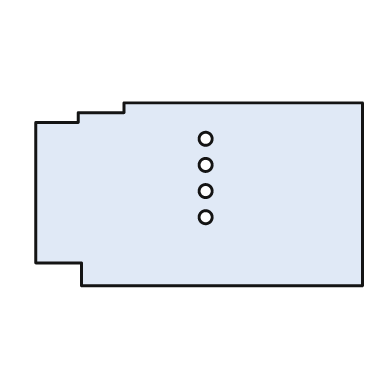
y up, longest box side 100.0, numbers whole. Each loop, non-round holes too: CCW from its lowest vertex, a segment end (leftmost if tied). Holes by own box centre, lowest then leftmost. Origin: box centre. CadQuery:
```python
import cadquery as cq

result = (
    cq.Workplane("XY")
    .moveTo(-36.0, -28.0)
    .lineTo(50.0, -28.0)
    .lineTo(50.0, 28.0)
    .lineTo(-23.0, 28.0)
    .lineTo(-23.0, 25.0)
    .lineTo(-37.0, 25.0)
    .lineTo(-37.0, 22.0)
    .lineTo(-50.0, 22.0)
    .lineTo(-50.0, -21.0)
    .lineTo(-36.0, -21.0)
    .close()
    .moveTo(2.0, -7.0)
    .circle(2.0)
    .moveTo(2.0, 1.0)
    .circle(2.0)
    .moveTo(2.0, 9.0)
    .circle(2.0)
    .moveTo(2.0, 17.0)
    .circle(2.0)
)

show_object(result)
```